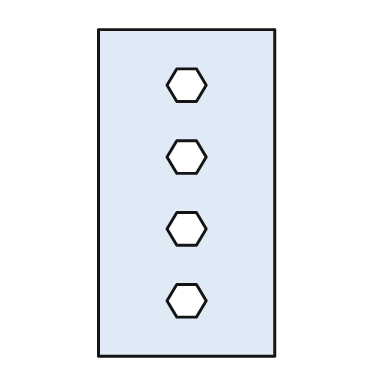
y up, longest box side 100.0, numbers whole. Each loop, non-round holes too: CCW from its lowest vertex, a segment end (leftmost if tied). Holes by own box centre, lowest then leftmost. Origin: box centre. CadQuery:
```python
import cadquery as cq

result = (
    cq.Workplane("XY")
    .moveTo(-27.0, -50.0)
    .lineTo(27.0, -50.0)
    .lineTo(27.0, 50.0)
    .lineTo(-27.0, 50.0)
    .close()
    .moveTo(-3.0, -38.0)
    .lineTo(3.0, -38.0)
    .lineTo(6.0, -33.0)
    .lineTo(3.0, -28.0)
    .lineTo(-3.0, -28.0)
    .lineTo(-6.0, -33.0)
    .close()
    .moveTo(-3.0, -16.0)
    .lineTo(3.0, -16.0)
    .lineTo(6.0, -11.0)
    .lineTo(3.0, -6.0)
    .lineTo(-3.0, -6.0)
    .lineTo(-6.0, -11.0)
    .close()
    .moveTo(-3.0, 6.0)
    .lineTo(3.0, 6.0)
    .lineTo(6.0, 11.0)
    .lineTo(3.0, 16.0)
    .lineTo(-3.0, 16.0)
    .lineTo(-6.0, 11.0)
    .close()
    .moveTo(-3.0, 28.0)
    .lineTo(3.0, 28.0)
    .lineTo(6.0, 33.0)
    .lineTo(3.0, 38.0)
    .lineTo(-3.0, 38.0)
    .lineTo(-6.0, 33.0)
    .close()
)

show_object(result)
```